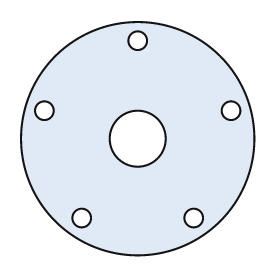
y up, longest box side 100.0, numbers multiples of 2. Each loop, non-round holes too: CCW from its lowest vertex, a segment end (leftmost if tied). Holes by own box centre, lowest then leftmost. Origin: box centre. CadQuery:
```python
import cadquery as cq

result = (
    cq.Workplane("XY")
    .moveTo(0.0, 0.0)
    .circle(50.0)
    .moveTo(-24.0, -34.0)
    .circle(4.0)
    .moveTo(24.0, -34.0)
    .circle(4.0)
    .moveTo(0.0, 0.0)
    .circle(12.0)
    .moveTo(-40.0, 12.0)
    .circle(4.0)
    .moveTo(40.0, 12.0)
    .circle(4.0)
    .moveTo(0.0, 42.0)
    .circle(4.0)
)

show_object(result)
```